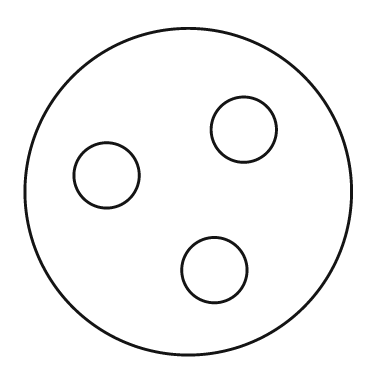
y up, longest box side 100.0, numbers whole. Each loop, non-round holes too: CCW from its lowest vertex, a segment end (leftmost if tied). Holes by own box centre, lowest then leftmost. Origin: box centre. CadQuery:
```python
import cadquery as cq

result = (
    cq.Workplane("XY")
    .moveTo(0.0, 0.0)
    .circle(50.0)
    .moveTo(8.0, -24.0)
    .circle(10.0)
    .moveTo(-25.0, 5.0)
    .circle(10.0)
    .moveTo(17.0, 19.0)
    .circle(10.0)
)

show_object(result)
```